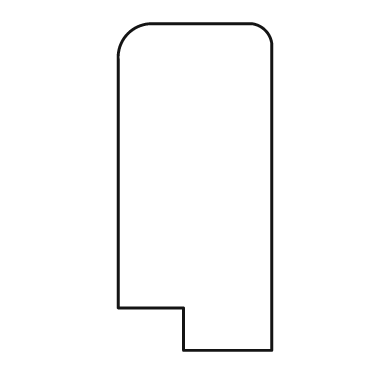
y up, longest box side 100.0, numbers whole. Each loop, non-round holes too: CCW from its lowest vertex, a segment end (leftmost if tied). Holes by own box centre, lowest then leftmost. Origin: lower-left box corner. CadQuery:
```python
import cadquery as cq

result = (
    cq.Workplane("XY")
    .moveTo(20.0, 0.0)
    .lineTo(47.0, 0.0)
    .lineTo(47.0, 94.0)
    .threePointArc((45.0, 98.0), (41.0, 100.0))
    .lineTo(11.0, 100.0)
    .threePointArc((3.0, 97.0), (0.0, 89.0))
    .lineTo(0.0, 13.0)
    .lineTo(20.0, 13.0)
    .close()
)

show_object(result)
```